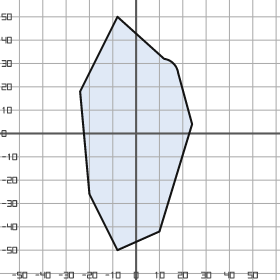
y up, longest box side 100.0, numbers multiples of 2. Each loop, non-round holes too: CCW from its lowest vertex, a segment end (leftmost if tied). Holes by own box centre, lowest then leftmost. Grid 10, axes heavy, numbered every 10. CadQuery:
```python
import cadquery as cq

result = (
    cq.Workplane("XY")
    .moveTo(-8.0, -50.0)
    .lineTo(10.0, -42.0)
    .lineTo(24.0, 4.0)
    .lineTo(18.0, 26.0)
    .threePointArc((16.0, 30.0), (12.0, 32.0))
    .lineTo(-8.0, 50.0)
    .lineTo(-24.0, 18.0)
    .lineTo(-20.0, -26.0)
    .close()
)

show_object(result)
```